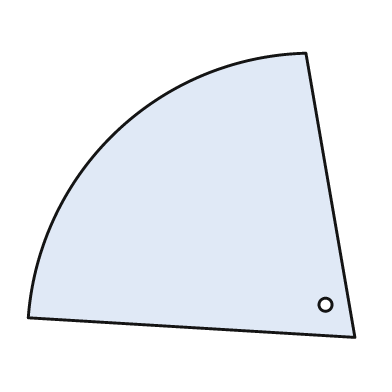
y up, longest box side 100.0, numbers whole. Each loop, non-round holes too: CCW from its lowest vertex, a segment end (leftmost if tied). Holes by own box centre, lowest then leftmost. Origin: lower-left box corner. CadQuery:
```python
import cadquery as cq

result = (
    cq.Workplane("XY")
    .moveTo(100.0, 0.0)
    .lineTo(85.0, 87.0)
    .threePointArc((27.0, 63.0), (0.0, 6.0))
    .close()
    .moveTo(91.0, 10.0)
    .circle(2.0)
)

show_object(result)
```